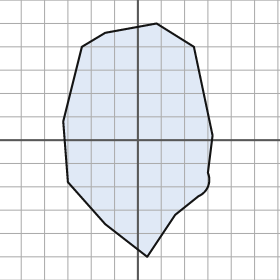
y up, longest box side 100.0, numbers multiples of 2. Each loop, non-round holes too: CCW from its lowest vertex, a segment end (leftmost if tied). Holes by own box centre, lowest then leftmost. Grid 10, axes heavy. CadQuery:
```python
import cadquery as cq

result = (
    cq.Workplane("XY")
    .moveTo(4.0, -50.0)
    .lineTo(16.0, -32.0)
    .lineTo(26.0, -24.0)
    .threePointArc((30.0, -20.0), (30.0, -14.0))
    .lineTo(32.0, 2.0)
    .lineTo(24.0, 40.0)
    .lineTo(8.0, 50.0)
    .lineTo(-14.0, 46.0)
    .lineTo(-24.0, 40.0)
    .lineTo(-32.0, 8.0)
    .lineTo(-30.0, -18.0)
    .lineTo(-14.0, -36.0)
    .close()
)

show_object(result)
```